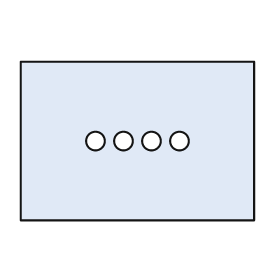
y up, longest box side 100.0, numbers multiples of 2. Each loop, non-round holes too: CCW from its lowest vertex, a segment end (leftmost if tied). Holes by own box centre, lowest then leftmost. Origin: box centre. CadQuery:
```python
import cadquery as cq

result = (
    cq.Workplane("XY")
    .moveTo(-50.0, -34.0)
    .lineTo(50.0, -34.0)
    .lineTo(50.0, 34.0)
    .lineTo(-50.0, 34.0)
    .close()
    .moveTo(-18.0, 0.0)
    .circle(4.0)
    .moveTo(-6.0, 0.0)
    .circle(4.0)
    .moveTo(6.0, 0.0)
    .circle(4.0)
    .moveTo(18.0, 0.0)
    .circle(4.0)
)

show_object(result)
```